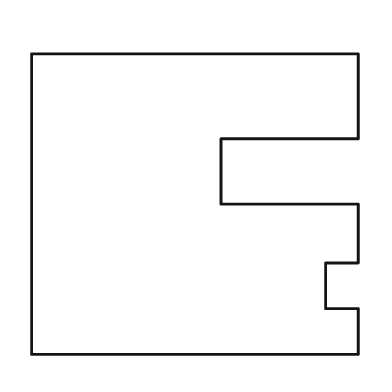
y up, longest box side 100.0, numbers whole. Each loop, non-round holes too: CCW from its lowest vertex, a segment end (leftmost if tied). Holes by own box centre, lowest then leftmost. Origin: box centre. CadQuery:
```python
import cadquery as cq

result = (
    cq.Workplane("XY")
    .moveTo(-50.0, -46.0)
    .lineTo(50.0, -46.0)
    .lineTo(50.0, -32.0)
    .lineTo(40.0, -32.0)
    .lineTo(40.0, -18.0)
    .lineTo(50.0, -18.0)
    .lineTo(50.0, 0.0)
    .lineTo(8.0, 0.0)
    .lineTo(8.0, 20.0)
    .lineTo(50.0, 20.0)
    .lineTo(50.0, 46.0)
    .lineTo(-50.0, 46.0)
    .close()
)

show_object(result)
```